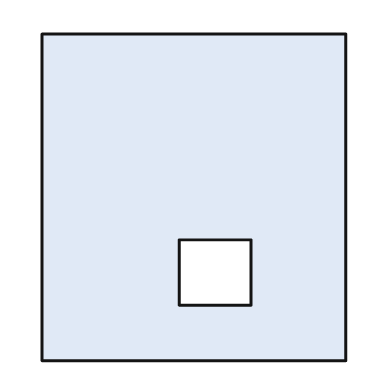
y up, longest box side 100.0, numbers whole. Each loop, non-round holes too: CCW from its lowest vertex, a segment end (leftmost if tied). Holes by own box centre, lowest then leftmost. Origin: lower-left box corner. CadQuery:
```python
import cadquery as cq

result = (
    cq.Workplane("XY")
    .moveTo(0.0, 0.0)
    .lineTo(93.0, 0.0)
    .lineTo(93.0, 100.0)
    .lineTo(0.0, 100.0)
    .close()
    .moveTo(42.0, 17.0)
    .lineTo(64.0, 17.0)
    .lineTo(64.0, 37.0)
    .lineTo(42.0, 37.0)
    .close()
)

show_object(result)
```